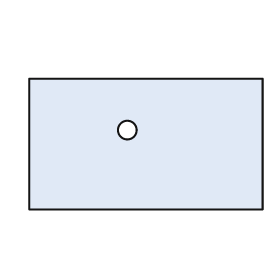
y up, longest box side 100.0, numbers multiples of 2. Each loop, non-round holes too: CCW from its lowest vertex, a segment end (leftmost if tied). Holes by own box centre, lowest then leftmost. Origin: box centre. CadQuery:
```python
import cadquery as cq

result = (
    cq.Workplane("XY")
    .moveTo(-50.0, -28.0)
    .lineTo(50.0, -28.0)
    .lineTo(50.0, 28.0)
    .lineTo(-50.0, 28.0)
    .close()
    .moveTo(-8.0, 6.0)
    .circle(4.0)
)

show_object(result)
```